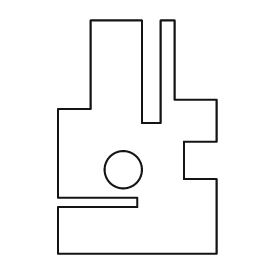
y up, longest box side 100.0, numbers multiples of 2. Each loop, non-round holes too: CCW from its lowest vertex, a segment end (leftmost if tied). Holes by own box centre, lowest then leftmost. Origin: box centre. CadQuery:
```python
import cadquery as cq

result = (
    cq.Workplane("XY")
    .moveTo(-34.0, -50.0)
    .lineTo(34.0, -50.0)
    .lineTo(34.0, -18.0)
    .lineTo(20.0, -18.0)
    .lineTo(20.0, -2.0)
    .lineTo(34.0, -2.0)
    .lineTo(34.0, 16.0)
    .lineTo(16.0, 16.0)
    .lineTo(16.0, 50.0)
    .lineTo(10.0, 50.0)
    .lineTo(10.0, 6.0)
    .lineTo(2.0, 6.0)
    .lineTo(2.0, 50.0)
    .lineTo(-20.0, 50.0)
    .lineTo(-20.0, 12.0)
    .lineTo(-34.0, 12.0)
    .lineTo(-34.0, -26.0)
    .lineTo(0.0, -26.0)
    .lineTo(0.0, -30.0)
    .lineTo(-34.0, -30.0)
    .close()
    .moveTo(-6.0, -14.0)
    .circle(8.0)
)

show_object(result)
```